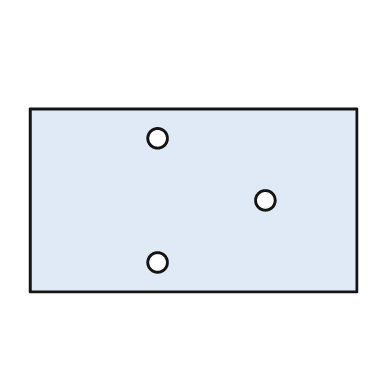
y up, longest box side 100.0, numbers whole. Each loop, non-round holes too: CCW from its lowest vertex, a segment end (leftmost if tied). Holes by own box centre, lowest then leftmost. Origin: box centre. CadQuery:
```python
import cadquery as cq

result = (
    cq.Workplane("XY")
    .moveTo(-50.0, -28.0)
    .lineTo(50.0, -28.0)
    .lineTo(50.0, 28.0)
    .lineTo(-50.0, 28.0)
    .close()
    .moveTo(-11.0, -19.0)
    .circle(3.0)
    .moveTo(22.0, 0.0)
    .circle(3.0)
    .moveTo(-11.0, 19.0)
    .circle(3.0)
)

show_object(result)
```